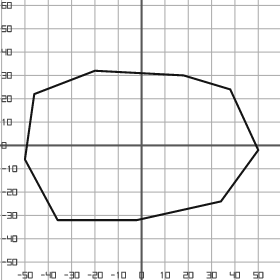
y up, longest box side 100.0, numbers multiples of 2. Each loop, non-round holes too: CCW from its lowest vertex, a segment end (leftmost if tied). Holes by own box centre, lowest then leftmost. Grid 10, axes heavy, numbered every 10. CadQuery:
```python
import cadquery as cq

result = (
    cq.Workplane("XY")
    .moveTo(-36.0, -32.0)
    .lineTo(-2.0, -32.0)
    .lineTo(34.0, -24.0)
    .lineTo(50.0, -2.0)
    .lineTo(38.0, 24.0)
    .lineTo(18.0, 30.0)
    .lineTo(-20.0, 32.0)
    .lineTo(-46.0, 22.0)
    .lineTo(-50.0, -6.0)
    .close()
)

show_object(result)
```